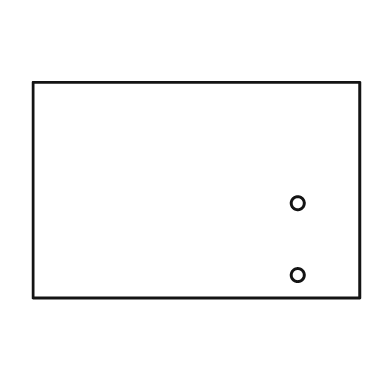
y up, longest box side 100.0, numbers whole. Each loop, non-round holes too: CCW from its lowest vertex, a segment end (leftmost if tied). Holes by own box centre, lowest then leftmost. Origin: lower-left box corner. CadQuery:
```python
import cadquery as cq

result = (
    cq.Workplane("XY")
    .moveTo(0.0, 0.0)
    .lineTo(100.0, 0.0)
    .lineTo(100.0, 66.0)
    .lineTo(0.0, 66.0)
    .close()
    .moveTo(81.0, 7.0)
    .circle(2.0)
    .moveTo(81.0, 29.0)
    .circle(2.0)
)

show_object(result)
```